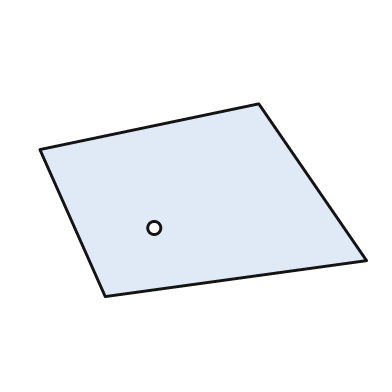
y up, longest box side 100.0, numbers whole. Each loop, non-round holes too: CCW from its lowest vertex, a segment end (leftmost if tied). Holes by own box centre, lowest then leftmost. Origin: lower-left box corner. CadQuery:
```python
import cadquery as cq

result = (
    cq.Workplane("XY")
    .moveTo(20.0, 0.0)
    .lineTo(100.0, 11.0)
    .lineTo(67.0, 59.0)
    .lineTo(0.0, 45.0)
    .close()
    .moveTo(35.0, 21.0)
    .circle(2.0)
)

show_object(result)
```